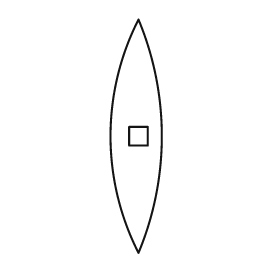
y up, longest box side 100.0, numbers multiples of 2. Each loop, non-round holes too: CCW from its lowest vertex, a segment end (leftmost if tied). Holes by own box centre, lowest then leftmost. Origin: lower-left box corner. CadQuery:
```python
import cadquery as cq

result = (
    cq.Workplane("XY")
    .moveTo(12.0, 0.0)
    .threePointArc((22.0, 50.0), (12.0, 100.0))
    .threePointArc((0.0, 50.0), (12.0, 0.0))
    .close()
    .moveTo(8.0, 46.0)
    .lineTo(16.0, 46.0)
    .lineTo(16.0, 54.0)
    .lineTo(8.0, 54.0)
    .close()
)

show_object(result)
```